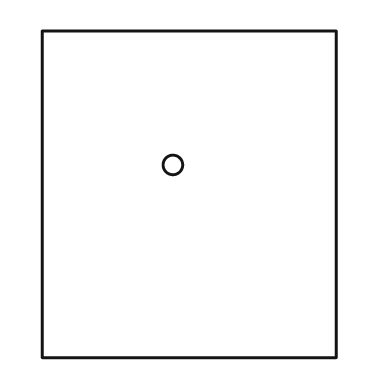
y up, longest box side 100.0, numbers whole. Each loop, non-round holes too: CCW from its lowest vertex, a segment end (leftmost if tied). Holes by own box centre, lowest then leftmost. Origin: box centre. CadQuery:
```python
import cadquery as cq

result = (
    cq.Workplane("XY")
    .moveTo(-45.0, -50.0)
    .lineTo(45.0, -50.0)
    .lineTo(45.0, 50.0)
    .lineTo(-45.0, 50.0)
    .close()
    .moveTo(-5.0, 9.0)
    .circle(3.0)
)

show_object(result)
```